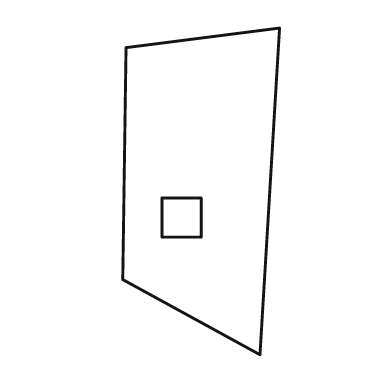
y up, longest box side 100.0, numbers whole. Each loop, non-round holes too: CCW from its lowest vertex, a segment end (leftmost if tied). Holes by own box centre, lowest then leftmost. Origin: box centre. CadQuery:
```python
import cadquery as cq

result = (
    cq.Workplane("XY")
    .moveTo(18.0, -50.0)
    .lineTo(24.0, 50.0)
    .lineTo(-23.0, 44.0)
    .lineTo(-24.0, -27.0)
    .close()
    .moveTo(-12.0, -14.0)
    .lineTo(0.0, -14.0)
    .lineTo(0.0, -2.0)
    .lineTo(-12.0, -2.0)
    .close()
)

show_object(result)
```